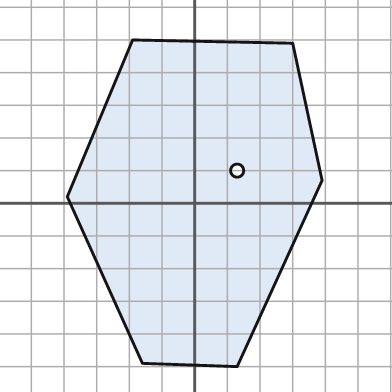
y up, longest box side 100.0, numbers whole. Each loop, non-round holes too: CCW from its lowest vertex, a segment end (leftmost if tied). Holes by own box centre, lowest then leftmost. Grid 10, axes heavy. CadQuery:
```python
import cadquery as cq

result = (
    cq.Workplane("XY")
    .moveTo(13.0, -50.0)
    .lineTo(39.0, 7.0)
    .lineTo(30.0, 49.0)
    .lineTo(-19.0, 50.0)
    .lineTo(-39.0, 2.0)
    .lineTo(-16.0, -49.0)
    .close()
    .moveTo(13.0, 10.0)
    .circle(2.0)
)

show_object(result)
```